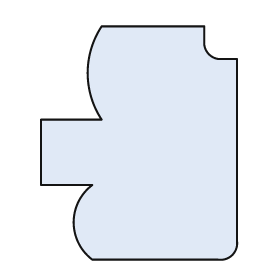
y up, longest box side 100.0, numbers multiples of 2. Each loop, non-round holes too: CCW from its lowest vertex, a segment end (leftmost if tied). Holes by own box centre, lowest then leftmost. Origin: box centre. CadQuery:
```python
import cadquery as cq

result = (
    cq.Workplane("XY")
    .moveTo(-20.0, -50.0)
    .lineTo(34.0, -50.0)
    .threePointArc((40.0, -48.0), (42.0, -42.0))
    .lineTo(42.0, 36.0)
    .lineTo(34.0, 36.0)
    .threePointArc((30.0, 38.0), (28.0, 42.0))
    .lineTo(28.0, 50.0)
    .lineTo(-16.0, 50.0)
    .threePointArc((-22.0, 30.0), (-16.0, 10.0))
    .lineTo(-42.0, 10.0)
    .lineTo(-42.0, -18.0)
    .lineTo(-20.0, -18.0)
    .threePointArc((-28.0, -34.0), (-20.0, -50.0))
    .close()
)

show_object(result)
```